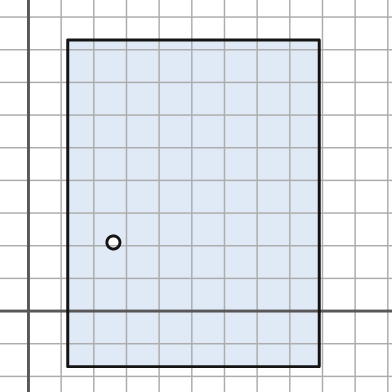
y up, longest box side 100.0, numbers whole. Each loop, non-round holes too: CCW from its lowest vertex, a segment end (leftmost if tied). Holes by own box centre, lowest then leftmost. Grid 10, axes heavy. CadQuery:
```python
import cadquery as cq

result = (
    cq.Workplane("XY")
    .moveTo(12.0, -17.0)
    .lineTo(89.0, -17.0)
    .lineTo(89.0, 83.0)
    .lineTo(12.0, 83.0)
    .close()
    .moveTo(26.0, 21.0)
    .circle(2.0)
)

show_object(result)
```